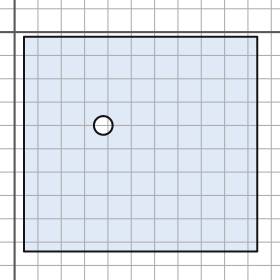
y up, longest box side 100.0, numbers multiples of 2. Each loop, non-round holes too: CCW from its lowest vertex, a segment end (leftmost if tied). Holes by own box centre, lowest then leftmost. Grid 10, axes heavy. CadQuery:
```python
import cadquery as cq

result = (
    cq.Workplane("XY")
    .moveTo(4.0, -94.0)
    .lineTo(104.0, -94.0)
    .lineTo(104.0, -2.0)
    .lineTo(4.0, -2.0)
    .close()
    .moveTo(38.0, -40.0)
    .circle(4.0)
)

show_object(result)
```